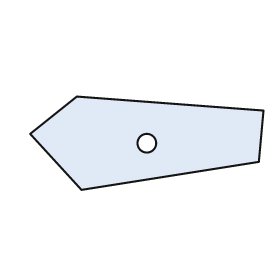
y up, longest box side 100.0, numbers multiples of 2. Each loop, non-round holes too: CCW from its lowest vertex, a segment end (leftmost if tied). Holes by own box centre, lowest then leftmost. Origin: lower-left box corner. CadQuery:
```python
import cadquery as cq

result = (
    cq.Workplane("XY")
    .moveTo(22.0, 0.0)
    .lineTo(98.0, 12.0)
    .lineTo(100.0, 34.0)
    .lineTo(20.0, 40.0)
    .lineTo(0.0, 24.0)
    .close()
    .moveTo(50.0, 20.0)
    .circle(4.0)
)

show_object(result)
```